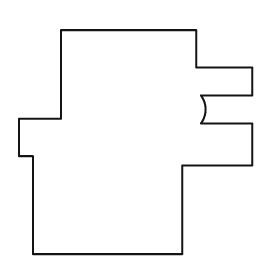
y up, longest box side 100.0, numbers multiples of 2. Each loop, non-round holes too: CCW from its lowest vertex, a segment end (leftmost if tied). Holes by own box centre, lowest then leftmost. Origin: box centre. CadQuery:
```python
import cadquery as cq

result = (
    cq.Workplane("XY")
    .moveTo(-44.0, -48.0)
    .lineTo(20.0, -48.0)
    .lineTo(20.0, -10.0)
    .lineTo(50.0, -10.0)
    .lineTo(50.0, 8.0)
    .lineTo(28.0, 8.0)
    .threePointArc((30.0, 14.0), (28.0, 20.0))
    .lineTo(50.0, 20.0)
    .lineTo(50.0, 32.0)
    .lineTo(26.0, 32.0)
    .lineTo(26.0, 48.0)
    .lineTo(-32.0, 48.0)
    .lineTo(-32.0, 10.0)
    .lineTo(-50.0, 10.0)
    .lineTo(-50.0, -6.0)
    .lineTo(-44.0, -6.0)
    .close()
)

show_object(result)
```